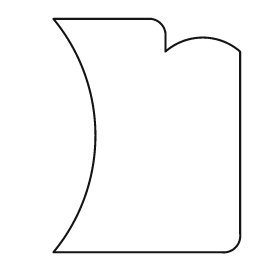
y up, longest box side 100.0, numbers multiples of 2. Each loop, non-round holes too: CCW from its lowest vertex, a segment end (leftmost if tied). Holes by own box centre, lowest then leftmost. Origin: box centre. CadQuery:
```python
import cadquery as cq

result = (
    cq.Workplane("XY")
    .moveTo(-40.0, -50.0)
    .lineTo(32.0, -50.0)
    .threePointArc((38.0, -48.0), (40.0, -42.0))
    .lineTo(40.0, 36.0)
    .threePointArc((24.0, 42.0), (8.0, 36.0))
    .lineTo(8.0, 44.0)
    .threePointArc((6.0, 48.0), (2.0, 50.0))
    .lineTo(-40.0, 50.0)
    .threePointArc((-22.0, 0.0), (-40.0, -50.0))
    .close()
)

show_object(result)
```